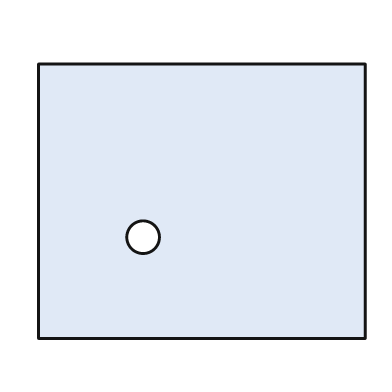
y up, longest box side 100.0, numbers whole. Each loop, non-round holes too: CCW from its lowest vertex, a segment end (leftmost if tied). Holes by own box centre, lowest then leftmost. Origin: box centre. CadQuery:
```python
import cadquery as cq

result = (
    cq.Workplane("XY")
    .moveTo(-50.0, -42.0)
    .lineTo(50.0, -42.0)
    .lineTo(50.0, 42.0)
    .lineTo(-50.0, 42.0)
    .close()
    .moveTo(-18.0, -11.0)
    .circle(5.0)
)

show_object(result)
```